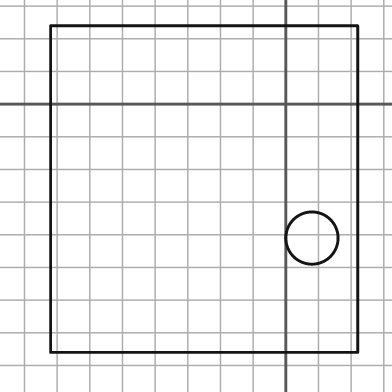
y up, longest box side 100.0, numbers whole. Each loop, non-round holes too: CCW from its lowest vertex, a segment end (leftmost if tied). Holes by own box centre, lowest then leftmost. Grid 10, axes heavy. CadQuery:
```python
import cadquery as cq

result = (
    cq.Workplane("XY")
    .moveTo(-72.0, -76.0)
    .lineTo(22.0, -76.0)
    .lineTo(22.0, 24.0)
    .lineTo(-72.0, 24.0)
    .close()
    .moveTo(8.0, -41.0)
    .circle(8.0)
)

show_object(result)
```